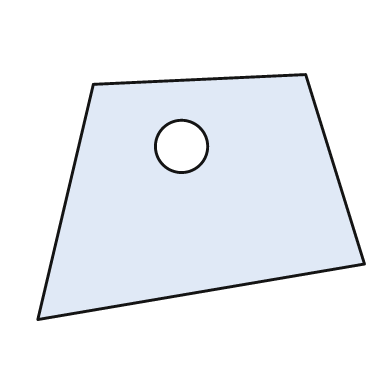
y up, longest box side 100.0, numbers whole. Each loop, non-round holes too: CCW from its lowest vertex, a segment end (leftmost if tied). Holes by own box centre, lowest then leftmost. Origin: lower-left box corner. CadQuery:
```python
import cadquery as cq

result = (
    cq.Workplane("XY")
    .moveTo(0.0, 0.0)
    .lineTo(100.0, 17.0)
    .lineTo(82.0, 75.0)
    .lineTo(17.0, 72.0)
    .close()
    .moveTo(44.0, 53.0)
    .circle(8.0)
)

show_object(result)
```